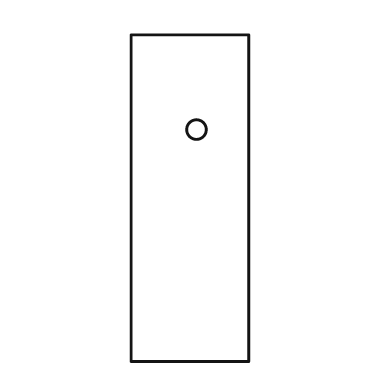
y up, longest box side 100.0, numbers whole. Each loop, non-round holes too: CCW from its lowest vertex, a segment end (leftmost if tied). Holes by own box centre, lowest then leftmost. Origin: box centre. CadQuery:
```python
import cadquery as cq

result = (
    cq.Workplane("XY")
    .moveTo(-18.0, -50.0)
    .lineTo(18.0, -50.0)
    .lineTo(18.0, 50.0)
    .lineTo(-18.0, 50.0)
    .close()
    .moveTo(2.0, 21.0)
    .circle(3.0)
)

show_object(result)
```